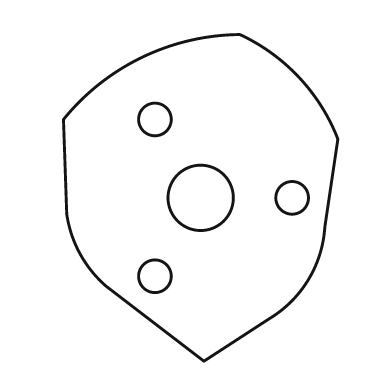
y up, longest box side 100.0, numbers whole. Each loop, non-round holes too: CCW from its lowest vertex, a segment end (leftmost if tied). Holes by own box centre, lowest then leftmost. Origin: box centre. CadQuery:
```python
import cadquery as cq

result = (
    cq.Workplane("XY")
    .moveTo(1.0, -50.0)
    .lineTo(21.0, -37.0)
    .threePointArc((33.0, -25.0), (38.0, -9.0))
    .lineTo(42.0, 18.0)
    .threePointArc((30.0, 37.0), (12.0, 50.0))
    .threePointArc((-18.0, 43.0), (-42.0, 24.0))
    .lineTo(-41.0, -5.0)
    .threePointArc((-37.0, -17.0), (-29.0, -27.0))
    .close()
    .moveTo(-14.0, -24.0)
    .circle(5.0)
    .moveTo(0.0, 0.0)
    .circle(10.0)
    .moveTo(28.0, 0.0)
    .circle(5.0)
    .moveTo(-14.0, 24.0)
    .circle(5.0)
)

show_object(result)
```